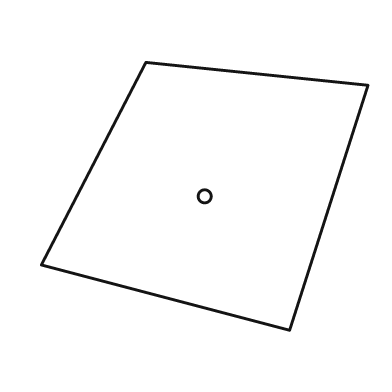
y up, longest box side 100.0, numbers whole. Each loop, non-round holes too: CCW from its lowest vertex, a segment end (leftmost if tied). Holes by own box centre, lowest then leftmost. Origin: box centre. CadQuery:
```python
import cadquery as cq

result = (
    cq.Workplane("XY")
    .moveTo(26.0, -41.0)
    .lineTo(50.0, 34.0)
    .lineTo(-18.0, 41.0)
    .lineTo(-50.0, -21.0)
    .close()
    .moveTo(0.0, 0.0)
    .circle(2.0)
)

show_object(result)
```